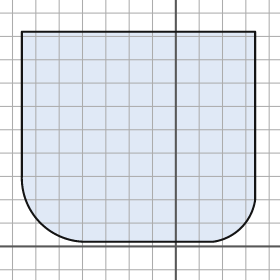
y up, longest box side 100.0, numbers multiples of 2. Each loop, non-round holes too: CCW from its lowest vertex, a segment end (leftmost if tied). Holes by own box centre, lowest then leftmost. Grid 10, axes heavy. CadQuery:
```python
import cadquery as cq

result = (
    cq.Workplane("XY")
    .moveTo(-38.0, 2.0)
    .lineTo(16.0, 2.0)
    .threePointArc((28.0, 8.0), (34.0, 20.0))
    .lineTo(34.0, 92.0)
    .lineTo(-66.0, 92.0)
    .lineTo(-66.0, 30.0)
    .threePointArc((-58.0, 10.0), (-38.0, 2.0))
    .close()
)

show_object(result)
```